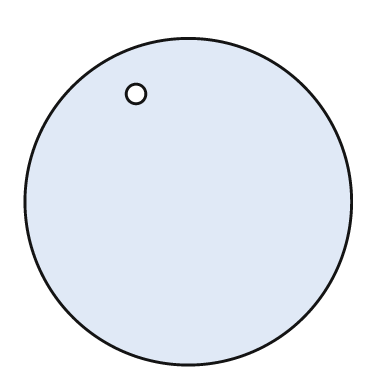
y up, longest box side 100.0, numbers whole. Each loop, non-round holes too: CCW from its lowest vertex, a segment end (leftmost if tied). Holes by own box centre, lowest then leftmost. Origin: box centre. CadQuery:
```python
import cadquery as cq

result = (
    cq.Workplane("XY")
    .moveTo(0.0, 0.0)
    .circle(50.0)
    .moveTo(-16.0, 33.0)
    .circle(3.0)
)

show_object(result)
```